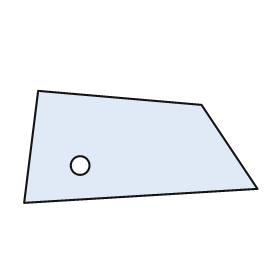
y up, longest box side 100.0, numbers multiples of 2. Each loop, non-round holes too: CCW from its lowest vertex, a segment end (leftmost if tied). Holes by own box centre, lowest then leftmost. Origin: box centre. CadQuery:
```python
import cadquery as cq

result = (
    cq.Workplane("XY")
    .moveTo(-50.0, -24.0)
    .lineTo(50.0, -18.0)
    .lineTo(26.0, 18.0)
    .lineTo(-44.0, 24.0)
    .close()
    .moveTo(-26.0, -8.0)
    .circle(4.0)
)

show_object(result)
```